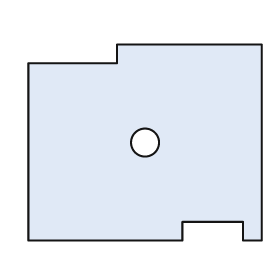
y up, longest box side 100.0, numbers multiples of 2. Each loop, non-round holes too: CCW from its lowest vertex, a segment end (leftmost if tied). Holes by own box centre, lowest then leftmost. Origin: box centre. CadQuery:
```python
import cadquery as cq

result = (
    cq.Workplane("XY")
    .moveTo(-50.0, -42.0)
    .lineTo(16.0, -42.0)
    .lineTo(16.0, -34.0)
    .lineTo(42.0, -34.0)
    .lineTo(42.0, -42.0)
    .lineTo(50.0, -42.0)
    .lineTo(50.0, 42.0)
    .lineTo(-12.0, 42.0)
    .lineTo(-12.0, 34.0)
    .lineTo(-50.0, 34.0)
    .close()
    .moveTo(0.0, 0.0)
    .circle(6.0)
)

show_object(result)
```